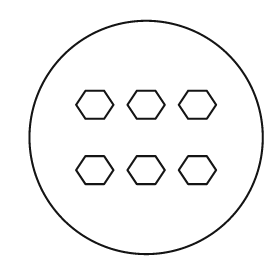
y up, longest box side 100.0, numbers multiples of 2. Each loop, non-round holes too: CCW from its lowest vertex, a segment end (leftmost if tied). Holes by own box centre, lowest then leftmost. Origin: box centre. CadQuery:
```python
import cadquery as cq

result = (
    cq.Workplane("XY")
    .moveTo(0.0, 0.0)
    .circle(50.0)
    .moveTo(-26.0, -20.0)
    .lineTo(-18.0, -20.0)
    .lineTo(-14.0, -14.0)
    .lineTo(-18.0, -8.0)
    .lineTo(-26.0, -8.0)
    .lineTo(-30.0, -14.0)
    .close()
    .moveTo(-4.0, -20.0)
    .lineTo(4.0, -20.0)
    .lineTo(8.0, -14.0)
    .lineTo(4.0, -8.0)
    .lineTo(-4.0, -8.0)
    .lineTo(-8.0, -14.0)
    .close()
    .moveTo(18.0, -20.0)
    .lineTo(26.0, -20.0)
    .lineTo(30.0, -14.0)
    .lineTo(26.0, -8.0)
    .lineTo(18.0, -8.0)
    .lineTo(14.0, -14.0)
    .close()
    .moveTo(-26.0, 8.0)
    .lineTo(-18.0, 8.0)
    .lineTo(-14.0, 14.0)
    .lineTo(-18.0, 20.0)
    .lineTo(-26.0, 20.0)
    .lineTo(-30.0, 14.0)
    .close()
    .moveTo(-4.0, 8.0)
    .lineTo(4.0, 8.0)
    .lineTo(8.0, 14.0)
    .lineTo(4.0, 20.0)
    .lineTo(-4.0, 20.0)
    .lineTo(-8.0, 14.0)
    .close()
    .moveTo(18.0, 8.0)
    .lineTo(26.0, 8.0)
    .lineTo(30.0, 14.0)
    .lineTo(26.0, 20.0)
    .lineTo(18.0, 20.0)
    .lineTo(14.0, 14.0)
    .close()
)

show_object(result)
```